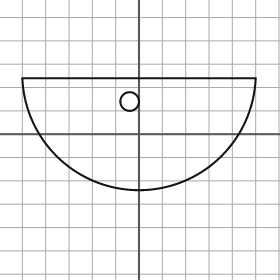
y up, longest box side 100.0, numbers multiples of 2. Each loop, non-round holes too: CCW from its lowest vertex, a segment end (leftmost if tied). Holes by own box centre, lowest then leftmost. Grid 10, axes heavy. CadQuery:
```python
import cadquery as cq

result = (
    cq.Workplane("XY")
    .moveTo(-50.0, 24.0)
    .threePointArc((0.0, -24.0), (50.0, 24.0))
    .close()
    .moveTo(-4.0, 14.0)
    .circle(4.0)
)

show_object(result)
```